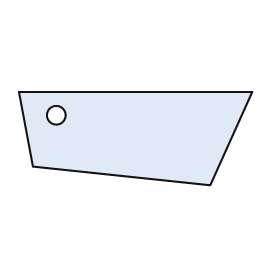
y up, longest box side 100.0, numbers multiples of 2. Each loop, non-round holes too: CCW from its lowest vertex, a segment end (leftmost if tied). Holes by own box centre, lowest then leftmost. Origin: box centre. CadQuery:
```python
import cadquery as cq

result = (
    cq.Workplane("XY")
    .moveTo(32.0, -20.0)
    .lineTo(50.0, 20.0)
    .lineTo(-50.0, 20.0)
    .lineTo(-44.0, -12.0)
    .close()
    .moveTo(-34.0, 10.0)
    .circle(4.0)
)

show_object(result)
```